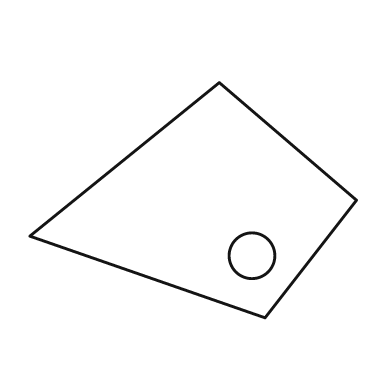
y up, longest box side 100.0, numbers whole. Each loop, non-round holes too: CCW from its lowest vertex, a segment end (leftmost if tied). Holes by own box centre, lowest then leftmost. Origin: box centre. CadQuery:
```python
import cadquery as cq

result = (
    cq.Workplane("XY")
    .moveTo(22.0, -36.0)
    .lineTo(50.0, 0.0)
    .lineTo(8.0, 36.0)
    .lineTo(-50.0, -11.0)
    .close()
    .moveTo(18.0, -17.0)
    .circle(7.0)
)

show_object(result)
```